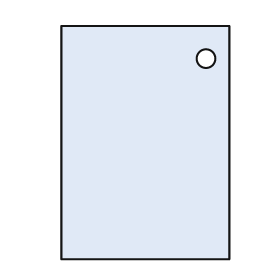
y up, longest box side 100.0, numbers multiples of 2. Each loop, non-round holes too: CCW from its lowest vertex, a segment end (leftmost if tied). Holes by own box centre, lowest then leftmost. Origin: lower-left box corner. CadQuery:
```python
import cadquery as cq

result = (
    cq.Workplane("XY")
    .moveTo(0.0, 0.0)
    .lineTo(72.0, 0.0)
    .lineTo(72.0, 100.0)
    .lineTo(0.0, 100.0)
    .close()
    .moveTo(62.0, 86.0)
    .circle(4.0)
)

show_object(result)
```